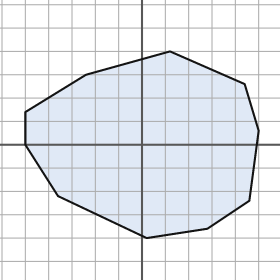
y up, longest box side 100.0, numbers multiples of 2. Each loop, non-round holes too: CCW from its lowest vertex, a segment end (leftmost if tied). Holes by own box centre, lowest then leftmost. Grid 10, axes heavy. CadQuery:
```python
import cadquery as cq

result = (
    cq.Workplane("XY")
    .moveTo(2.0, -40.0)
    .lineTo(28.0, -36.0)
    .lineTo(46.0, -24.0)
    .lineTo(50.0, 6.0)
    .lineTo(44.0, 26.0)
    .lineTo(12.0, 40.0)
    .lineTo(-24.0, 30.0)
    .lineTo(-50.0, 14.0)
    .lineTo(-50.0, 0.0)
    .lineTo(-36.0, -22.0)
    .close()
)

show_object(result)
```